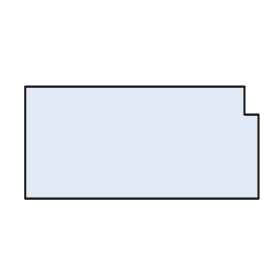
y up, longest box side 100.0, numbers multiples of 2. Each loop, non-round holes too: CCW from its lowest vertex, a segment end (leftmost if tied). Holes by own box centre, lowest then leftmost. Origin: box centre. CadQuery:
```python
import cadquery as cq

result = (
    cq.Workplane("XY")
    .moveTo(-50.0, -24.0)
    .lineTo(50.0, -24.0)
    .lineTo(50.0, 12.0)
    .lineTo(44.0, 12.0)
    .lineTo(44.0, 24.0)
    .lineTo(-50.0, 24.0)
    .close()
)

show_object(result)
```